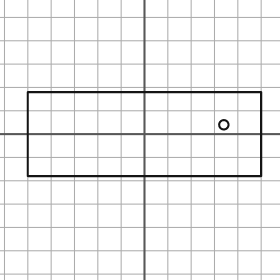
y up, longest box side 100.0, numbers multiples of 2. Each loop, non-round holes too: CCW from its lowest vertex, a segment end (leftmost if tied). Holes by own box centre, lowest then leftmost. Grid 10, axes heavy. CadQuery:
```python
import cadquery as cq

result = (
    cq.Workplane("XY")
    .moveTo(-50.0, -18.0)
    .lineTo(50.0, -18.0)
    .lineTo(50.0, 18.0)
    .lineTo(-50.0, 18.0)
    .close()
    .moveTo(34.0, 4.0)
    .circle(2.0)
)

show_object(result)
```